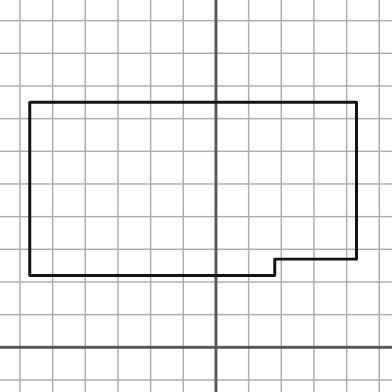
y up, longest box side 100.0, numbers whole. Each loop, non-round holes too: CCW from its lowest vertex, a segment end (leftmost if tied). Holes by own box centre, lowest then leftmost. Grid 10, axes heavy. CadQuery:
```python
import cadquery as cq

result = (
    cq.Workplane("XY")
    .moveTo(-57.0, 22.0)
    .lineTo(18.0, 22.0)
    .lineTo(18.0, 27.0)
    .lineTo(43.0, 27.0)
    .lineTo(43.0, 75.0)
    .lineTo(-57.0, 75.0)
    .close()
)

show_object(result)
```